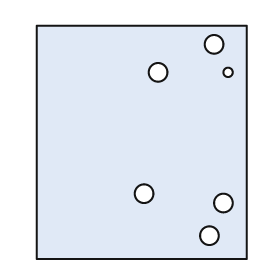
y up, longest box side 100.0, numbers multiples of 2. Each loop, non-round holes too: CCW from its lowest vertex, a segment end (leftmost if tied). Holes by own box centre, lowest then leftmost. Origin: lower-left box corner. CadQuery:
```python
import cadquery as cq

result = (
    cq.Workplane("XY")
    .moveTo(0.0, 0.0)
    .lineTo(90.0, 0.0)
    .lineTo(90.0, 100.0)
    .lineTo(0.0, 100.0)
    .close()
    .moveTo(74.0, 10.0)
    .circle(4.0)
    .moveTo(80.0, 24.0)
    .circle(4.0)
    .moveTo(46.0, 28.0)
    .circle(4.0)
    .moveTo(52.0, 80.0)
    .circle(4.0)
    .moveTo(82.0, 80.0)
    .circle(2.0)
    .moveTo(76.0, 92.0)
    .circle(4.0)
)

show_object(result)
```